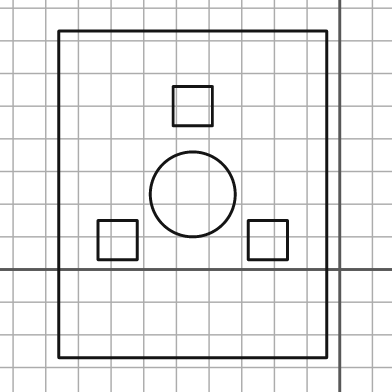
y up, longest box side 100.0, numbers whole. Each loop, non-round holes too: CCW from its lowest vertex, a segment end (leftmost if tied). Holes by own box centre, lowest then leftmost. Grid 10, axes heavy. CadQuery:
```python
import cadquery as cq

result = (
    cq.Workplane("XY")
    .moveTo(-86.0, -27.0)
    .lineTo(-4.0, -27.0)
    .lineTo(-4.0, 73.0)
    .lineTo(-86.0, 73.0)
    .close()
    .moveTo(-74.0, 3.0)
    .lineTo(-62.0, 3.0)
    .lineTo(-62.0, 15.0)
    .lineTo(-74.0, 15.0)
    .close()
    .moveTo(-28.0, 3.0)
    .lineTo(-16.0, 3.0)
    .lineTo(-16.0, 15.0)
    .lineTo(-28.0, 15.0)
    .close()
    .moveTo(-45.0, 23.0)
    .circle(13.0)
    .moveTo(-51.0, 44.0)
    .lineTo(-39.0, 44.0)
    .lineTo(-39.0, 56.0)
    .lineTo(-51.0, 56.0)
    .close()
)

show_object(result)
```